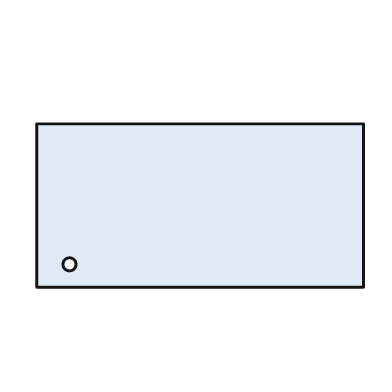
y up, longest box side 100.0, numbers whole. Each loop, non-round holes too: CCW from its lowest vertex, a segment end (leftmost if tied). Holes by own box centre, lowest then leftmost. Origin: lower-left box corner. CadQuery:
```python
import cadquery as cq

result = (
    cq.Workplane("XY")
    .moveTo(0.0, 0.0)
    .lineTo(100.0, 0.0)
    .lineTo(100.0, 50.0)
    .lineTo(0.0, 50.0)
    .close()
    .moveTo(10.0, 7.0)
    .circle(2.0)
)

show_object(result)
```